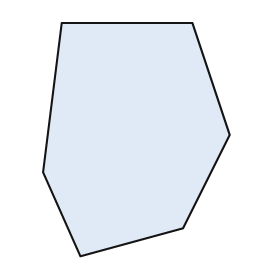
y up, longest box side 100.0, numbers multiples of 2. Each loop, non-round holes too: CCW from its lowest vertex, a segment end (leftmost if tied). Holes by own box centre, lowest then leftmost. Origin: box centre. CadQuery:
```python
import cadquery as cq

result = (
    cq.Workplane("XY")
    .moveTo(-24.0, -50.0)
    .lineTo(20.0, -38.0)
    .lineTo(40.0, 2.0)
    .lineTo(24.0, 50.0)
    .lineTo(-32.0, 50.0)
    .lineTo(-40.0, -14.0)
    .close()
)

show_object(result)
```